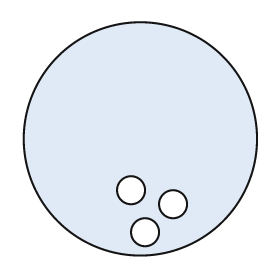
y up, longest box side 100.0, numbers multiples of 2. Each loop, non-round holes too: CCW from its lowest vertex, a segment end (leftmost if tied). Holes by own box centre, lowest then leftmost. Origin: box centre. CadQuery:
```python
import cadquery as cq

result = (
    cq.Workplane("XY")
    .moveTo(0.0, 0.0)
    .circle(50.0)
    .moveTo(2.0, -40.0)
    .circle(6.0)
    .moveTo(14.0, -28.0)
    .circle(6.0)
    .moveTo(-4.0, -22.0)
    .circle(6.0)
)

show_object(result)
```